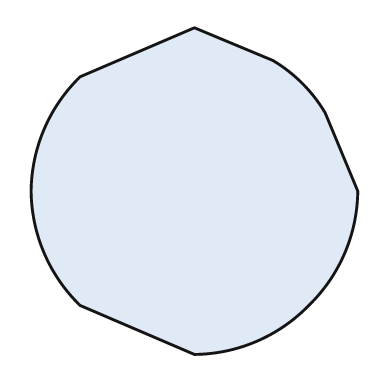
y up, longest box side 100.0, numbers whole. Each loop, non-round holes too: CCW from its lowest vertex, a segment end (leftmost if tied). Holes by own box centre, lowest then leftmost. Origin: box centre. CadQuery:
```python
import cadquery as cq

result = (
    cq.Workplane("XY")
    .moveTo(0.0, -50.0)
    .threePointArc((19.0, -46.0), (35.0, -35.0))
    .threePointArc((46.0, -19.0), (50.0, 0.0))
    .lineTo(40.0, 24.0)
    .threePointArc((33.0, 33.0), (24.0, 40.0))
    .lineTo(0.0, 50.0)
    .lineTo(-35.0, 35.0)
    .threePointArc((-46.0, 19.0), (-50.0, 0.0))
    .threePointArc((-46.0, -19.0), (-35.0, -35.0))
    .close()
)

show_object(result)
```